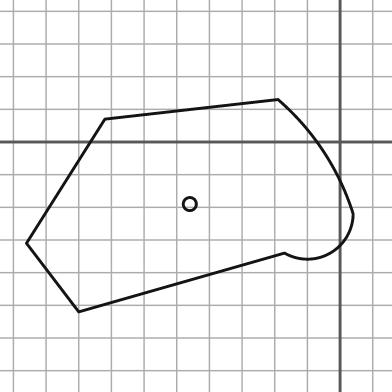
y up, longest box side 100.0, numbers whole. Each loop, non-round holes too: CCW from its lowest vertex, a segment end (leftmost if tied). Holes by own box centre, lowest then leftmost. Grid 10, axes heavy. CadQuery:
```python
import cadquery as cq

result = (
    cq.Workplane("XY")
    .moveTo(-80.0, -52.0)
    .lineTo(-17.0, -34.0)
    .threePointArc((-3.0, -34.0), (4.0, -22.0))
    .threePointArc((-5.0, -3.0), (-19.0, 13.0))
    .lineTo(-72.0, 7.0)
    .lineTo(-96.0, -31.0)
    .close()
    .moveTo(-46.0, -19.0)
    .circle(2.0)
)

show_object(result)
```